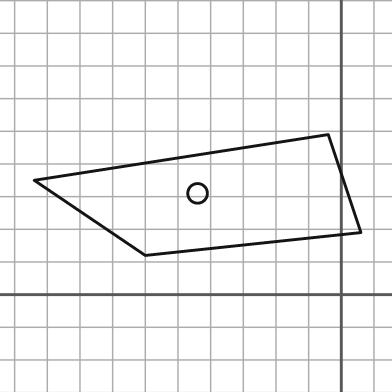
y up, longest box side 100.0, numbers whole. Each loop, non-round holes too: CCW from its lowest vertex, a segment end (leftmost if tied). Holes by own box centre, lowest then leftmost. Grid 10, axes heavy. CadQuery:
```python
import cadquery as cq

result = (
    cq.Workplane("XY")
    .moveTo(-60.0, 12.0)
    .lineTo(6.0, 19.0)
    .lineTo(-4.0, 49.0)
    .lineTo(-94.0, 35.0)
    .close()
    .moveTo(-44.0, 31.0)
    .circle(3.0)
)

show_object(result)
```